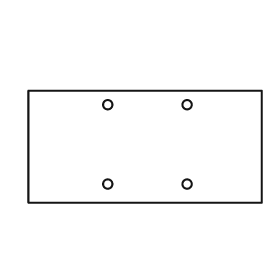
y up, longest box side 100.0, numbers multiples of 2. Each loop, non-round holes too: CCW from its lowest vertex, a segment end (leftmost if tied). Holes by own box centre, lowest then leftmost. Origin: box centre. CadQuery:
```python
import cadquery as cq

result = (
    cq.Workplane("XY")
    .moveTo(-50.0, -24.0)
    .lineTo(50.0, -24.0)
    .lineTo(50.0, 24.0)
    .lineTo(-50.0, 24.0)
    .close()
    .moveTo(-16.0, -16.0)
    .circle(2.0)
    .moveTo(18.0, -16.0)
    .circle(2.0)
    .moveTo(-16.0, 18.0)
    .circle(2.0)
    .moveTo(18.0, 18.0)
    .circle(2.0)
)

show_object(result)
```